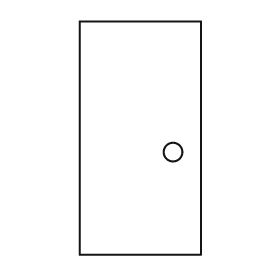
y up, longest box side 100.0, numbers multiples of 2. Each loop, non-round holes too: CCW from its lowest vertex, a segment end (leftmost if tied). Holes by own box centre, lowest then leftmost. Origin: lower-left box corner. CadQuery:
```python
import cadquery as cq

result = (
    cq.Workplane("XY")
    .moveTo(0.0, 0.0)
    .lineTo(52.0, 0.0)
    .lineTo(52.0, 100.0)
    .lineTo(0.0, 100.0)
    .close()
    .moveTo(40.0, 44.0)
    .circle(4.0)
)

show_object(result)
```